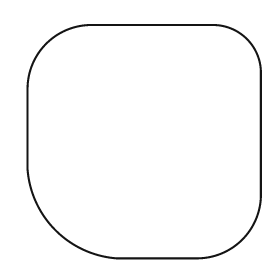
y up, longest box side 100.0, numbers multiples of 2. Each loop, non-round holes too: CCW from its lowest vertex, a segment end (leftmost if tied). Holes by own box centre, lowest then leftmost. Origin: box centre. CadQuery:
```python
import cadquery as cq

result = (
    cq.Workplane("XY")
    .moveTo(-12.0, -50.0)
    .lineTo(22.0, -50.0)
    .threePointArc((42.0, -42.0), (50.0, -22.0))
    .lineTo(50.0, 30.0)
    .threePointArc((44.0, 44.0), (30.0, 50.0))
    .lineTo(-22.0, 50.0)
    .threePointArc((-42.0, 42.0), (-50.0, 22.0))
    .lineTo(-50.0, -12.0)
    .threePointArc((-38.0, -38.0), (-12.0, -50.0))
    .close()
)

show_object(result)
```